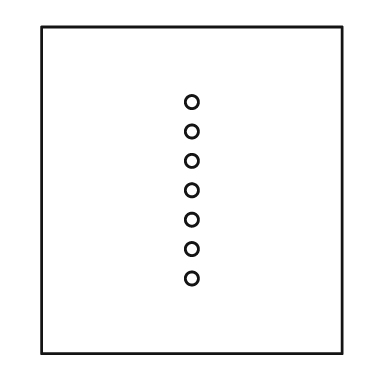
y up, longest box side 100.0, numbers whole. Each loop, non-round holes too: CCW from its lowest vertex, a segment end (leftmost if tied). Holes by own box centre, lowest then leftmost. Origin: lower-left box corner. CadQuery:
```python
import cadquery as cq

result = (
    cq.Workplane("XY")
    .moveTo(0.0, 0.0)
    .lineTo(92.0, 0.0)
    .lineTo(92.0, 100.0)
    .lineTo(0.0, 100.0)
    .close()
    .moveTo(46.0, 23.0)
    .circle(2.0)
    .moveTo(46.0, 32.0)
    .circle(2.0)
    .moveTo(46.0, 41.0)
    .circle(2.0)
    .moveTo(46.0, 50.0)
    .circle(2.0)
    .moveTo(46.0, 59.0)
    .circle(2.0)
    .moveTo(46.0, 68.0)
    .circle(2.0)
    .moveTo(46.0, 77.0)
    .circle(2.0)
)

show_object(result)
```